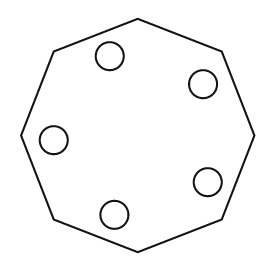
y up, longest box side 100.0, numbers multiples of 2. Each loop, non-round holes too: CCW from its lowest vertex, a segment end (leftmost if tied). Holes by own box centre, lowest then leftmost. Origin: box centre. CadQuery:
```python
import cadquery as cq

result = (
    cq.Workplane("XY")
    .moveTo(0.0, -50.0)
    .lineTo(36.0, -36.0)
    .lineTo(50.0, 0.0)
    .lineTo(36.0, 36.0)
    .lineTo(0.0, 50.0)
    .lineTo(-36.0, 36.0)
    .lineTo(-50.0, 0.0)
    .lineTo(-36.0, -36.0)
    .close()
    .moveTo(-10.0, -34.0)
    .circle(6.0)
    .moveTo(30.0, -20.0)
    .circle(6.0)
    .moveTo(-36.0, -2.0)
    .circle(6.0)
    .moveTo(28.0, 22.0)
    .circle(6.0)
    .moveTo(-12.0, 34.0)
    .circle(6.0)
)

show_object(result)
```